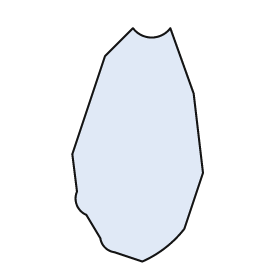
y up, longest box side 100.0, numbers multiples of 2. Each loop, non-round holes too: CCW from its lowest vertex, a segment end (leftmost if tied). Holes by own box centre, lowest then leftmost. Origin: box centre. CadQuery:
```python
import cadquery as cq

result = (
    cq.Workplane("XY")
    .moveTo(2.0, -50.0)
    .threePointArc((12.0, -44.0), (20.0, -36.0))
    .lineTo(28.0, -12.0)
    .lineTo(24.0, 22.0)
    .lineTo(14.0, 50.0)
    .threePointArc((6.0, 46.0), (-2.0, 50.0))
    .lineTo(-14.0, 38.0)
    .lineTo(-28.0, -4.0)
    .lineTo(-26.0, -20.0)
    .threePointArc((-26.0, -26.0), (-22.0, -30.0))
    .lineTo(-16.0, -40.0)
    .threePointArc((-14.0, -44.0), (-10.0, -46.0))
    .close()
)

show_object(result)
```